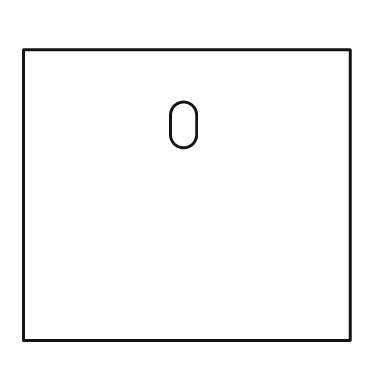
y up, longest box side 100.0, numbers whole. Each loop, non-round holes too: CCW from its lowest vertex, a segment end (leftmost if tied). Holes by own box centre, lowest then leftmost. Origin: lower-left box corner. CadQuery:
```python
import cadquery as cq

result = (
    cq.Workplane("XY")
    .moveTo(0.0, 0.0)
    .lineTo(100.0, 0.0)
    .lineTo(100.0, 89.0)
    .lineTo(0.0, 89.0)
    .close()
    .moveTo(45.0, 63.0)
    .threePointArc((49.0, 59.0), (53.0, 63.0))
    .lineTo(53.0, 69.0)
    .threePointArc((49.0, 73.0), (45.0, 69.0))
    .close()
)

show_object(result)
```